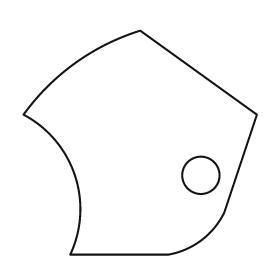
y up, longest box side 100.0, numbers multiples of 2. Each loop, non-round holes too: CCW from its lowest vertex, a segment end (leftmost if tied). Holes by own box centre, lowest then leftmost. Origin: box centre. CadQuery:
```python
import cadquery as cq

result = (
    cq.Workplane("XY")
    .moveTo(-30.0, -48.0)
    .lineTo(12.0, -48.0)
    .threePointArc((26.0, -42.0), (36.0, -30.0))
    .lineTo(50.0, 12.0)
    .lineTo(0.0, 48.0)
    .threePointArc((-28.0, 34.0), (-50.0, 12.0))
    .threePointArc((-28.0, -14.0), (-30.0, -48.0))
    .close()
    .moveTo(26.0, -14.0)
    .circle(8.0)
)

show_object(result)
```